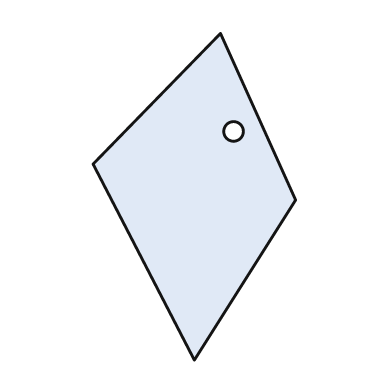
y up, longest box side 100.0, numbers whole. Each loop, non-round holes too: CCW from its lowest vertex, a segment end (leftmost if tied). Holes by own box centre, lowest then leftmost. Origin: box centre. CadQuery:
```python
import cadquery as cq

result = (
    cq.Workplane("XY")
    .moveTo(0.0, -50.0)
    .lineTo(31.0, -1.0)
    .lineTo(8.0, 50.0)
    .lineTo(-31.0, 10.0)
    .close()
    .moveTo(12.0, 20.0)
    .circle(3.0)
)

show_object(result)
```